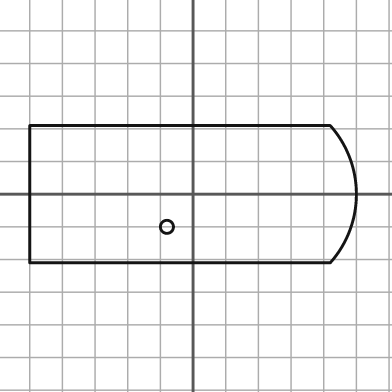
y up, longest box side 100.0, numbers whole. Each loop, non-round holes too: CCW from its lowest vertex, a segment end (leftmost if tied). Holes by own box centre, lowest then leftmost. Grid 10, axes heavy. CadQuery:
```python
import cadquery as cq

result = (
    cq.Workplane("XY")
    .moveTo(-50.0, -21.0)
    .lineTo(42.0, -21.0)
    .threePointArc((50.0, 0.0), (42.0, 21.0))
    .lineTo(-50.0, 21.0)
    .close()
    .moveTo(-8.0, -10.0)
    .circle(2.0)
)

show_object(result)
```